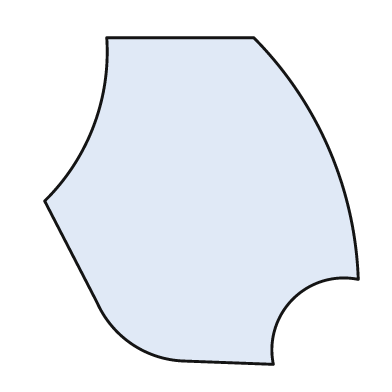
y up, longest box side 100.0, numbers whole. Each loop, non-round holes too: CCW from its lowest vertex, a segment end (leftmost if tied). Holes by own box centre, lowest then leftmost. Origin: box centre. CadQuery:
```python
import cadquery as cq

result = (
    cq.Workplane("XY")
    .moveTo(22.0, -50.0)
    .threePointArc((28.0, -30.0), (48.0, -24.0))
    .threePointArc((39.0, 16.0), (16.0, 50.0))
    .lineTo(-29.0, 50.0)
    .threePointArc((-33.0, 23.0), (-48.0, 0.0))
    .lineTo(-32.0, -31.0)
    .threePointArc((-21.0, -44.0), (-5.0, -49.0))
    .close()
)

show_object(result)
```